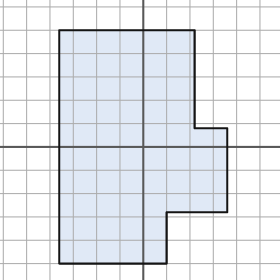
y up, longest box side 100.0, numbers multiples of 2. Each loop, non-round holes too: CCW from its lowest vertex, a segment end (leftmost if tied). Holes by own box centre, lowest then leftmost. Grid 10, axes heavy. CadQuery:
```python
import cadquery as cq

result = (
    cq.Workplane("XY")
    .moveTo(-36.0, -50.0)
    .lineTo(10.0, -50.0)
    .lineTo(10.0, -28.0)
    .lineTo(36.0, -28.0)
    .lineTo(36.0, 8.0)
    .lineTo(22.0, 8.0)
    .lineTo(22.0, 50.0)
    .lineTo(-36.0, 50.0)
    .close()
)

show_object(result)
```